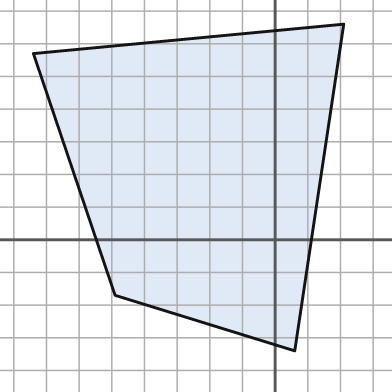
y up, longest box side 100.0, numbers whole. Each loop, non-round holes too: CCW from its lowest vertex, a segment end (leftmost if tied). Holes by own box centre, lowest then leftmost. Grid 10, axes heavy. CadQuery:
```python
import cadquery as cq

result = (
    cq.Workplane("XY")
    .moveTo(6.0, -34.0)
    .lineTo(21.0, 66.0)
    .lineTo(-74.0, 57.0)
    .lineTo(-49.0, -17.0)
    .close()
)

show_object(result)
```